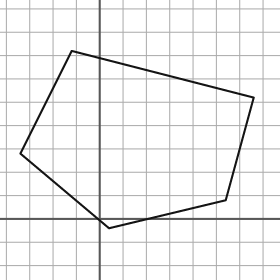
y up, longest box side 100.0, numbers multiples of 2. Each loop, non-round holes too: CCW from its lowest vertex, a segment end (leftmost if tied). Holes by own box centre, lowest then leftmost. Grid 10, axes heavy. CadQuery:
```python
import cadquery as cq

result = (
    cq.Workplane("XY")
    .moveTo(4.0, -4.0)
    .lineTo(54.0, 8.0)
    .lineTo(66.0, 52.0)
    .lineTo(-12.0, 72.0)
    .lineTo(-34.0, 28.0)
    .close()
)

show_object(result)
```